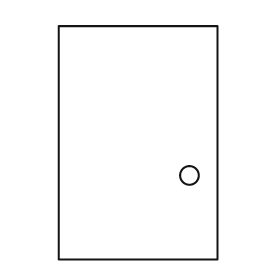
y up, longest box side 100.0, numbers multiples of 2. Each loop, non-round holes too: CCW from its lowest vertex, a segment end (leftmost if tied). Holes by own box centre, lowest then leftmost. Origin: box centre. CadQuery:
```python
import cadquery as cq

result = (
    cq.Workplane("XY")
    .moveTo(-34.0, -50.0)
    .lineTo(34.0, -50.0)
    .lineTo(34.0, 50.0)
    .lineTo(-34.0, 50.0)
    .close()
    .moveTo(22.0, -14.0)
    .circle(4.0)
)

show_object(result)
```